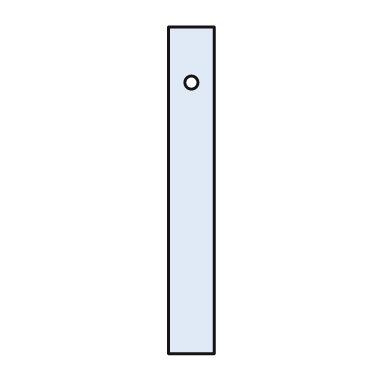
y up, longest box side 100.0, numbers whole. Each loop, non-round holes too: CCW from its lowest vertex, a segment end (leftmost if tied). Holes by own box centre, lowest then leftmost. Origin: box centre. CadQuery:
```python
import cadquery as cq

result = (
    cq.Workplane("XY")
    .moveTo(-7.0, -50.0)
    .lineTo(7.0, -50.0)
    .lineTo(7.0, 50.0)
    .lineTo(-7.0, 50.0)
    .close()
    .moveTo(0.0, 33.0)
    .circle(2.0)
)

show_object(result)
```